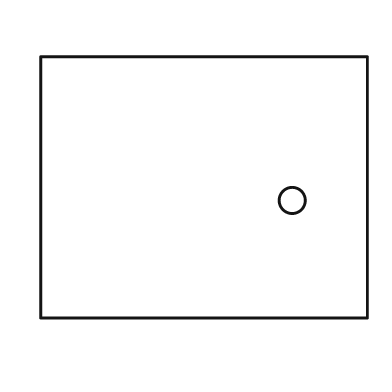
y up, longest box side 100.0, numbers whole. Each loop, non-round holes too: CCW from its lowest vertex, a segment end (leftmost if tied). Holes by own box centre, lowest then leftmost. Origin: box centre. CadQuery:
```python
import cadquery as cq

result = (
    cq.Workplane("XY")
    .moveTo(-50.0, -40.0)
    .lineTo(50.0, -40.0)
    .lineTo(50.0, 40.0)
    .lineTo(-50.0, 40.0)
    .close()
    .moveTo(27.0, -4.0)
    .circle(4.0)
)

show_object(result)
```